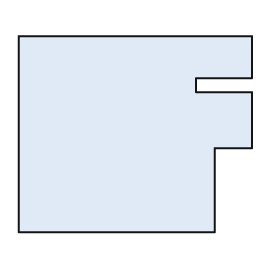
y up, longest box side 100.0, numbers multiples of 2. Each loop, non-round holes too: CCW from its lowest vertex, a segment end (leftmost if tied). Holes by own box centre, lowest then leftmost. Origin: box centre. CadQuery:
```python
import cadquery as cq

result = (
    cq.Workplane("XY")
    .moveTo(-50.0, -42.0)
    .lineTo(34.0, -42.0)
    .lineTo(34.0, -6.0)
    .lineTo(50.0, -6.0)
    .lineTo(50.0, 18.0)
    .lineTo(26.0, 18.0)
    .lineTo(26.0, 24.0)
    .lineTo(50.0, 24.0)
    .lineTo(50.0, 42.0)
    .lineTo(-50.0, 42.0)
    .close()
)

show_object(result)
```